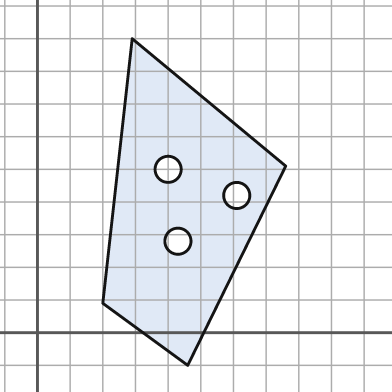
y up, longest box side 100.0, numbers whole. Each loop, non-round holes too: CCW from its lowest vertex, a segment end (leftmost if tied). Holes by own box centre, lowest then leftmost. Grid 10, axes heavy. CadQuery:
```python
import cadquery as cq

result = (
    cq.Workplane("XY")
    .moveTo(46.0, -10.0)
    .lineTo(76.0, 51.0)
    .lineTo(29.0, 90.0)
    .lineTo(20.0, 9.0)
    .close()
    .moveTo(43.0, 28.0)
    .circle(4.0)
    .moveTo(61.0, 42.0)
    .circle(4.0)
    .moveTo(40.0, 50.0)
    .circle(4.0)
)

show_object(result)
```